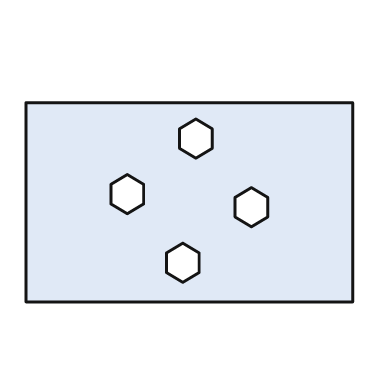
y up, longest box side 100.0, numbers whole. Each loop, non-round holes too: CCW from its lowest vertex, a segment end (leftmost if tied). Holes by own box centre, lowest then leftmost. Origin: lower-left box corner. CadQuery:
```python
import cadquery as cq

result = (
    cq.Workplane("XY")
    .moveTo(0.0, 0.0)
    .lineTo(100.0, 0.0)
    .lineTo(100.0, 61.0)
    .lineTo(0.0, 61.0)
    .close()
    .moveTo(48.0, 6.0)
    .lineTo(53.0, 9.0)
    .lineTo(53.0, 15.0)
    .lineTo(48.0, 18.0)
    .lineTo(43.0, 15.0)
    .lineTo(43.0, 9.0)
    .close()
    .moveTo(69.0, 23.0)
    .lineTo(74.0, 26.0)
    .lineTo(74.0, 32.0)
    .lineTo(69.0, 35.0)
    .lineTo(64.0, 32.0)
    .lineTo(64.0, 26.0)
    .close()
    .moveTo(31.0, 27.0)
    .lineTo(36.0, 30.0)
    .lineTo(36.0, 36.0)
    .lineTo(31.0, 39.0)
    .lineTo(26.0, 36.0)
    .lineTo(26.0, 30.0)
    .close()
    .moveTo(52.0, 44.0)
    .lineTo(57.0, 47.0)
    .lineTo(57.0, 53.0)
    .lineTo(52.0, 56.0)
    .lineTo(47.0, 53.0)
    .lineTo(47.0, 47.0)
    .close()
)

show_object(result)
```